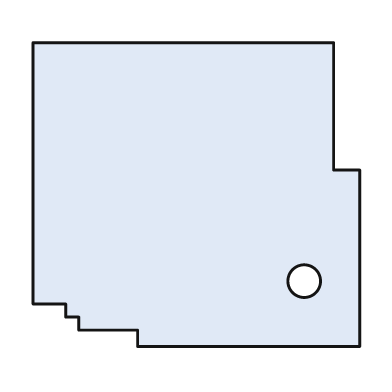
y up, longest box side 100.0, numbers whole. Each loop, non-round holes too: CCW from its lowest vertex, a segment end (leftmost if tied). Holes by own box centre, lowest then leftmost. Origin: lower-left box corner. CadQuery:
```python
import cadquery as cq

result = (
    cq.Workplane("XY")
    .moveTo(32.0, 0.0)
    .lineTo(100.0, 0.0)
    .lineTo(100.0, 54.0)
    .lineTo(92.0, 54.0)
    .lineTo(92.0, 93.0)
    .lineTo(0.0, 93.0)
    .lineTo(0.0, 13.0)
    .lineTo(10.0, 13.0)
    .lineTo(10.0, 9.0)
    .lineTo(14.0, 9.0)
    .lineTo(14.0, 5.0)
    .lineTo(32.0, 5.0)
    .close()
    .moveTo(83.0, 20.0)
    .circle(5.0)
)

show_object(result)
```